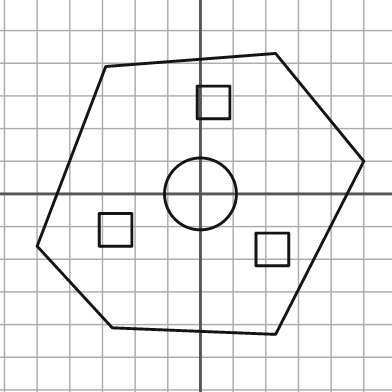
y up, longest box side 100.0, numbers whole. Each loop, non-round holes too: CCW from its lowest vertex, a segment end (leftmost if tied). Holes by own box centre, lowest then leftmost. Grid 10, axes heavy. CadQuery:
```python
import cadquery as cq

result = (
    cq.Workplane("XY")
    .moveTo(23.0, -43.0)
    .lineTo(50.0, 10.0)
    .lineTo(23.0, 43.0)
    .lineTo(-29.0, 39.0)
    .lineTo(-50.0, -16.0)
    .lineTo(-27.0, -41.0)
    .close()
    .moveTo(17.0, -22.0)
    .lineTo(27.0, -22.0)
    .lineTo(27.0, -12.0)
    .lineTo(17.0, -12.0)
    .close()
    .moveTo(-31.0, -16.0)
    .lineTo(-21.0, -16.0)
    .lineTo(-21.0, -6.0)
    .lineTo(-31.0, -6.0)
    .close()
    .moveTo(0.0, 0.0)
    .circle(11.0)
    .moveTo(-1.0, 23.0)
    .lineTo(9.0, 23.0)
    .lineTo(9.0, 33.0)
    .lineTo(-1.0, 33.0)
    .close()
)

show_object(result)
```